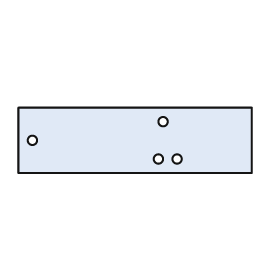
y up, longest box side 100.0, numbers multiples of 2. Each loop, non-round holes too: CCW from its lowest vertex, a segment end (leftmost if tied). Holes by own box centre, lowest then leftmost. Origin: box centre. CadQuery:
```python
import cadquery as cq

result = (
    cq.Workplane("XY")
    .moveTo(-50.0, -14.0)
    .lineTo(50.0, -14.0)
    .lineTo(50.0, 14.0)
    .lineTo(-50.0, 14.0)
    .close()
    .moveTo(10.0, -8.0)
    .circle(2.0)
    .moveTo(18.0, -8.0)
    .circle(2.0)
    .moveTo(-44.0, 0.0)
    .circle(2.0)
    .moveTo(12.0, 8.0)
    .circle(2.0)
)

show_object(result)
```